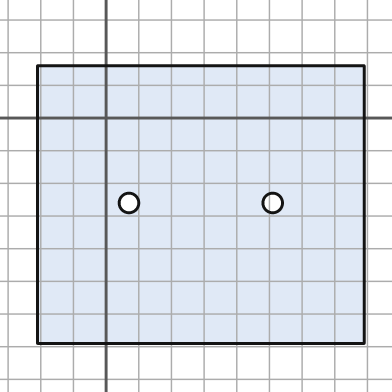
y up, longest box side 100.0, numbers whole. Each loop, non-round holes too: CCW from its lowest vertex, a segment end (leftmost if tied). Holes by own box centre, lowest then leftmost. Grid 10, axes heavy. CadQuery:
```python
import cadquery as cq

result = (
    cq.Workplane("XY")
    .moveTo(-21.0, -69.0)
    .lineTo(79.0, -69.0)
    .lineTo(79.0, 16.0)
    .lineTo(-21.0, 16.0)
    .close()
    .moveTo(7.0, -26.0)
    .circle(3.0)
    .moveTo(51.0, -26.0)
    .circle(3.0)
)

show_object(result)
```